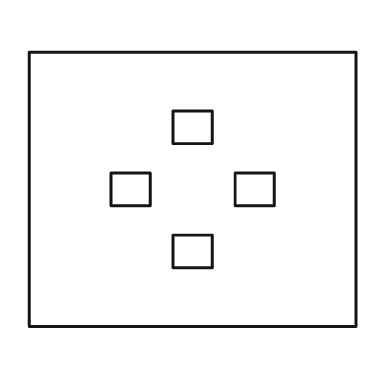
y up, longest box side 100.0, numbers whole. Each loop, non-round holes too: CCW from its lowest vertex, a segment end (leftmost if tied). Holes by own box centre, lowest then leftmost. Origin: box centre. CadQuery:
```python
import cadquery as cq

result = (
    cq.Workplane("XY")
    .moveTo(-50.0, -42.0)
    .lineTo(50.0, -42.0)
    .lineTo(50.0, 42.0)
    .lineTo(-50.0, 42.0)
    .close()
    .moveTo(-6.0, -24.0)
    .lineTo(6.0, -24.0)
    .lineTo(6.0, -14.0)
    .lineTo(-6.0, -14.0)
    .close()
    .moveTo(-25.0, -5.0)
    .lineTo(-13.0, -5.0)
    .lineTo(-13.0, 5.0)
    .lineTo(-25.0, 5.0)
    .close()
    .moveTo(13.0, -5.0)
    .lineTo(25.0, -5.0)
    .lineTo(25.0, 5.0)
    .lineTo(13.0, 5.0)
    .close()
    .moveTo(-6.0, 14.0)
    .lineTo(6.0, 14.0)
    .lineTo(6.0, 24.0)
    .lineTo(-6.0, 24.0)
    .close()
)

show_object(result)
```